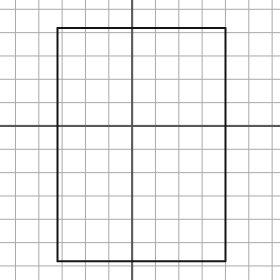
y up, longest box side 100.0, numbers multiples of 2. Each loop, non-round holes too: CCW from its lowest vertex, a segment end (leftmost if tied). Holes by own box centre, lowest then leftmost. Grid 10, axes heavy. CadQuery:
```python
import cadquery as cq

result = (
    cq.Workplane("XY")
    .moveTo(-32.0, -58.0)
    .lineTo(40.0, -58.0)
    .lineTo(40.0, 42.0)
    .lineTo(-32.0, 42.0)
    .close()
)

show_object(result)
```